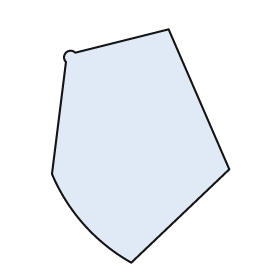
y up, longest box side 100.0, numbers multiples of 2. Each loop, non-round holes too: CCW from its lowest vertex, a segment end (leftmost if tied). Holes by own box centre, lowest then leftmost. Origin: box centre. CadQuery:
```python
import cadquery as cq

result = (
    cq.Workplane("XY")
    .moveTo(-4.0, -50.0)
    .lineTo(38.0, -10.0)
    .lineTo(12.0, 50.0)
    .lineTo(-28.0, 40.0)
    .threePointArc((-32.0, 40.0), (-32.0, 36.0))
    .lineTo(-38.0, -12.0)
    .threePointArc((-24.0, -34.0), (-4.0, -50.0))
    .close()
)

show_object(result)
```